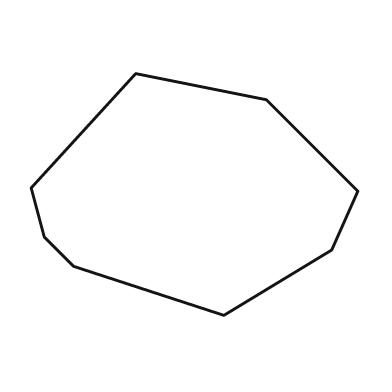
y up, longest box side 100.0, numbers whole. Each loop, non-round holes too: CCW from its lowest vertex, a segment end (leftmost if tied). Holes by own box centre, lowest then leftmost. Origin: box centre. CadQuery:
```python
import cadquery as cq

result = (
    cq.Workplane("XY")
    .moveTo(9.0, -37.0)
    .lineTo(42.0, -17.0)
    .lineTo(50.0, 1.0)
    .lineTo(22.0, 29.0)
    .lineTo(-18.0, 37.0)
    .lineTo(-50.0, 2.0)
    .lineTo(-46.0, -13.0)
    .lineTo(-37.0, -22.0)
    .close()
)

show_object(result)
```